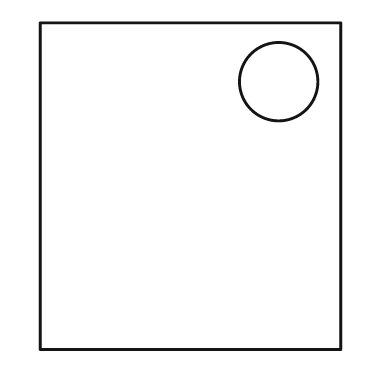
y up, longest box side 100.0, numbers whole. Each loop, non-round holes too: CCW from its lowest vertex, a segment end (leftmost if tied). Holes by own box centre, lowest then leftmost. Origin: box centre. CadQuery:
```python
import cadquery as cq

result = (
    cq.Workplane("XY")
    .moveTo(-46.0, -50.0)
    .lineTo(46.0, -50.0)
    .lineTo(46.0, 50.0)
    .lineTo(-46.0, 50.0)
    .close()
    .moveTo(27.0, 32.0)
    .circle(12.0)
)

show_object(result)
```